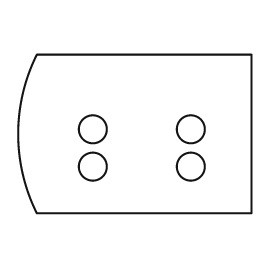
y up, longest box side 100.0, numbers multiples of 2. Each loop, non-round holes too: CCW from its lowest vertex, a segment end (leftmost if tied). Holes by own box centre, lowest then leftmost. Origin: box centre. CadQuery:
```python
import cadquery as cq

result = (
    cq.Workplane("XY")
    .moveTo(-42.0, -34.0)
    .lineTo(50.0, -34.0)
    .lineTo(50.0, 34.0)
    .lineTo(-42.0, 34.0)
    .threePointArc((-50.0, 0.0), (-42.0, -34.0))
    .close()
    .moveTo(-18.0, -14.0)
    .circle(6.0)
    .moveTo(24.0, -14.0)
    .circle(6.0)
    .moveTo(-18.0, 2.0)
    .circle(6.0)
    .moveTo(24.0, 2.0)
    .circle(6.0)
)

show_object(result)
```